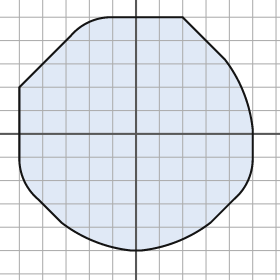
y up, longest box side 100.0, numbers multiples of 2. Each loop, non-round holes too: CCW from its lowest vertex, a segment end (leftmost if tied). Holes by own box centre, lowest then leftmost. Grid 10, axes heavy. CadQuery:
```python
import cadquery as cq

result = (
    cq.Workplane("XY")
    .moveTo(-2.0, -50.0)
    .lineTo(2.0, -50.0)
    .threePointArc((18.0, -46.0), (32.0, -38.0))
    .lineTo(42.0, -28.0)
    .threePointArc((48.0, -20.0), (50.0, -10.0))
    .lineTo(50.0, 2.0)
    .threePointArc((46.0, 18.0), (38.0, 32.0))
    .lineTo(20.0, 50.0)
    .lineTo(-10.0, 50.0)
    .threePointArc((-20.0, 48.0), (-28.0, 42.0))
    .lineTo(-50.0, 20.0)
    .lineTo(-50.0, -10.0)
    .threePointArc((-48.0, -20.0), (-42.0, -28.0))
    .lineTo(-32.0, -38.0)
    .threePointArc((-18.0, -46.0), (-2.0, -50.0))
    .close()
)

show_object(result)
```